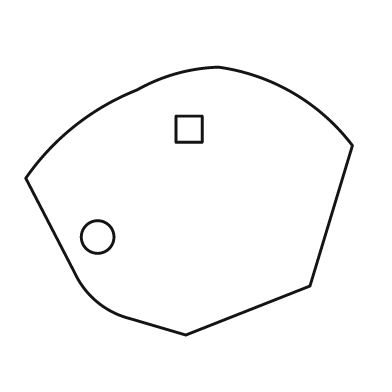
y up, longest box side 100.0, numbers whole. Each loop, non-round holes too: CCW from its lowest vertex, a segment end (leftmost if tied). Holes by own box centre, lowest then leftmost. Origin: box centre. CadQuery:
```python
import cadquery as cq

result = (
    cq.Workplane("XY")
    .moveTo(-1.0, -41.0)
    .lineTo(37.0, -26.0)
    .lineTo(50.0, 17.0)
    .threePointArc((32.0, 33.0), (9.0, 41.0))
    .threePointArc((-4.0, 39.0), (-16.0, 34.0))
    .threePointArc((-35.0, 23.0), (-50.0, 7.0))
    .lineTo(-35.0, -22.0)
    .threePointArc((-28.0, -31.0), (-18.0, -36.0))
    .close()
    .moveTo(-28.0, -11.0)
    .circle(5.0)
    .moveTo(-4.0, 18.0)
    .lineTo(4.0, 18.0)
    .lineTo(4.0, 26.0)
    .lineTo(-4.0, 26.0)
    .close()
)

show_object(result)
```